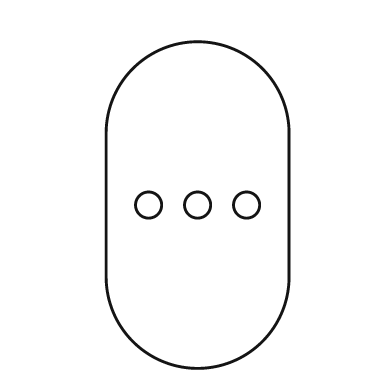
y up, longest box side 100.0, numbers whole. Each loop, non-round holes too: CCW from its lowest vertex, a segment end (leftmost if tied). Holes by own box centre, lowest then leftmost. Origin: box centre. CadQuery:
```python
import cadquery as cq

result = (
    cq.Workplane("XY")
    .moveTo(-28.0, -22.0)
    .threePointArc((0.0, -50.0), (28.0, -22.0))
    .lineTo(28.0, 22.0)
    .threePointArc((0.0, 50.0), (-28.0, 22.0))
    .close()
    .moveTo(-15.0, 0.0)
    .circle(4.0)
    .moveTo(0.0, 0.0)
    .circle(4.0)
    .moveTo(15.0, 0.0)
    .circle(4.0)
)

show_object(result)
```